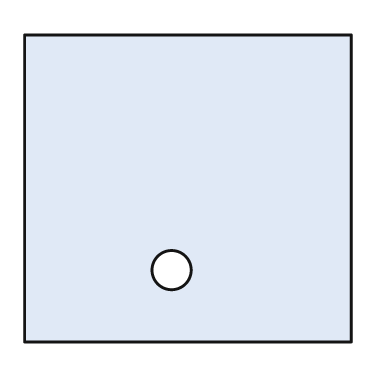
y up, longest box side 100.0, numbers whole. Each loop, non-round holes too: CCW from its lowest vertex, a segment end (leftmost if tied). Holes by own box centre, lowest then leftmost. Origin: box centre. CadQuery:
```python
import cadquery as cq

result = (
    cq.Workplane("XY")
    .moveTo(-50.0, -47.0)
    .lineTo(50.0, -47.0)
    .lineTo(50.0, 47.0)
    .lineTo(-50.0, 47.0)
    .close()
    .moveTo(-5.0, -25.0)
    .circle(6.0)
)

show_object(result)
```